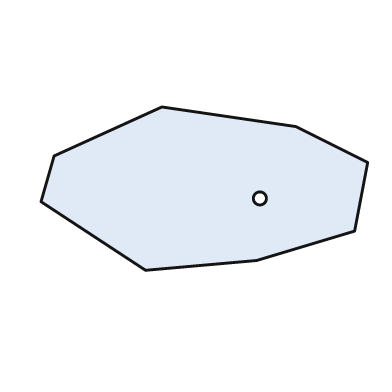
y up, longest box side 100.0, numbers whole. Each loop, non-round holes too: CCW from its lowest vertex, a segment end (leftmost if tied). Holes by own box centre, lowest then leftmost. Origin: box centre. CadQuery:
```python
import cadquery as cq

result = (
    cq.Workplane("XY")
    .moveTo(-18.0, -25.0)
    .lineTo(16.0, -22.0)
    .lineTo(46.0, -13.0)
    .lineTo(50.0, 8.0)
    .lineTo(28.0, 19.0)
    .lineTo(-13.0, 25.0)
    .lineTo(-46.0, 10.0)
    .lineTo(-50.0, -4.0)
    .close()
    .moveTo(17.0, -3.0)
    .circle(2.0)
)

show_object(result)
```